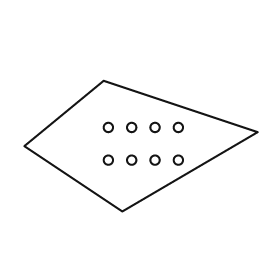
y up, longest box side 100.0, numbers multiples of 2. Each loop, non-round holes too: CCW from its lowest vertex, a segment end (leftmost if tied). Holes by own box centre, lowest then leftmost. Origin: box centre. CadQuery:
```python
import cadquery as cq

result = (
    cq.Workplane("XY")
    .moveTo(-8.0, -28.0)
    .lineTo(50.0, 6.0)
    .lineTo(-16.0, 28.0)
    .lineTo(-50.0, 0.0)
    .close()
    .moveTo(-14.0, -6.0)
    .circle(2.0)
    .moveTo(-4.0, -6.0)
    .circle(2.0)
    .moveTo(6.0, -6.0)
    .circle(2.0)
    .moveTo(16.0, -6.0)
    .circle(2.0)
    .moveTo(-14.0, 8.0)
    .circle(2.0)
    .moveTo(-4.0, 8.0)
    .circle(2.0)
    .moveTo(6.0, 8.0)
    .circle(2.0)
    .moveTo(16.0, 8.0)
    .circle(2.0)
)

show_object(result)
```